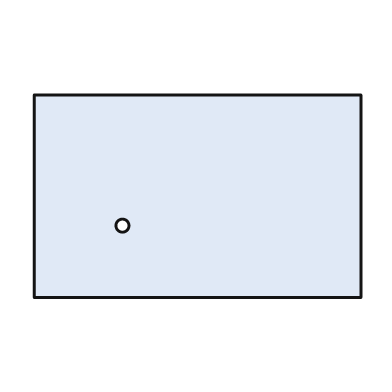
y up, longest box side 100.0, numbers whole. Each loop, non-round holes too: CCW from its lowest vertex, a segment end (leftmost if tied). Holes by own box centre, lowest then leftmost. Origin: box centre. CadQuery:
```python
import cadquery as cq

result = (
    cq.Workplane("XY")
    .moveTo(-50.0, -31.0)
    .lineTo(50.0, -31.0)
    .lineTo(50.0, 31.0)
    .lineTo(-50.0, 31.0)
    .close()
    .moveTo(-23.0, -9.0)
    .circle(2.0)
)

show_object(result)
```